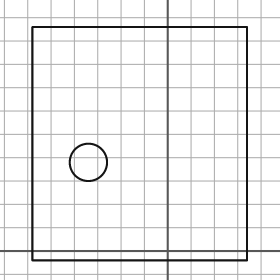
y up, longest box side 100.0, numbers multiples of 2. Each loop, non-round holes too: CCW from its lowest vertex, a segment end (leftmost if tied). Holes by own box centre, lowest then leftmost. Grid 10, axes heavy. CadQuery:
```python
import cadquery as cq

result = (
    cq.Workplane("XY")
    .moveTo(-58.0, -4.0)
    .lineTo(34.0, -4.0)
    .lineTo(34.0, 96.0)
    .lineTo(-58.0, 96.0)
    .close()
    .moveTo(-34.0, 38.0)
    .circle(8.0)
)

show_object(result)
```